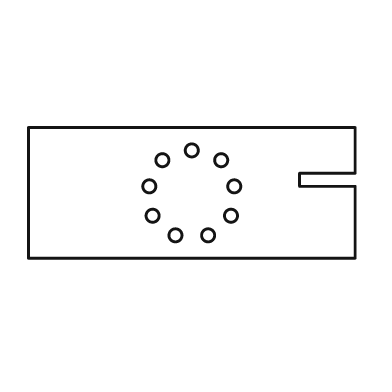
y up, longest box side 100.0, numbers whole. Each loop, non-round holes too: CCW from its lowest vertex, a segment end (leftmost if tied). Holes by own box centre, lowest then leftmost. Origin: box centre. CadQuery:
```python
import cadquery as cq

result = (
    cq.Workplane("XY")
    .moveTo(-50.0, -20.0)
    .lineTo(50.0, -20.0)
    .lineTo(50.0, 2.0)
    .lineTo(33.0, 2.0)
    .lineTo(33.0, 6.0)
    .lineTo(50.0, 6.0)
    .lineTo(50.0, 20.0)
    .lineTo(-50.0, 20.0)
    .close()
    .moveTo(-5.0, -13.0)
    .circle(2.0)
    .moveTo(5.0, -13.0)
    .circle(2.0)
    .moveTo(-12.0, -7.0)
    .circle(2.0)
    .moveTo(12.0, -7.0)
    .circle(2.0)
    .moveTo(-13.0, 2.0)
    .circle(2.0)
    .moveTo(13.0, 2.0)
    .circle(2.0)
    .moveTo(-9.0, 10.0)
    .circle(2.0)
    .moveTo(9.0, 10.0)
    .circle(2.0)
    .moveTo(0.0, 13.0)
    .circle(2.0)
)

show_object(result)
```